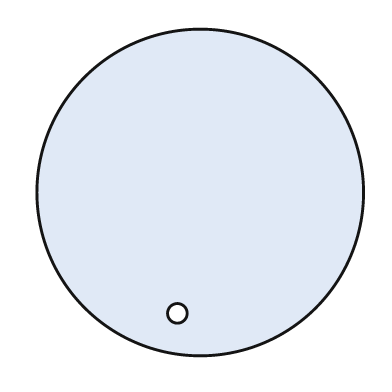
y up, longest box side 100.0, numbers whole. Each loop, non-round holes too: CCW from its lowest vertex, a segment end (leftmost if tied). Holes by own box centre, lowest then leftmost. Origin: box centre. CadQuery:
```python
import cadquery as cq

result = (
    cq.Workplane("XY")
    .moveTo(0.0, 0.0)
    .circle(50.0)
    .moveTo(-7.0, -37.0)
    .circle(3.0)
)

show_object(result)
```